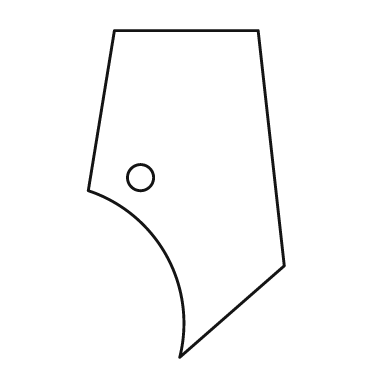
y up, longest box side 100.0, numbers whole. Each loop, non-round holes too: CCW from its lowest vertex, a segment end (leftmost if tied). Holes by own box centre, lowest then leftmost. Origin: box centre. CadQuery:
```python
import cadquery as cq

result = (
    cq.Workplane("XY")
    .moveTo(-2.0, -50.0)
    .lineTo(30.0, -22.0)
    .lineTo(22.0, 50.0)
    .lineTo(-22.0, 50.0)
    .lineTo(-30.0, 1.0)
    .threePointArc((-6.0, -19.0), (-2.0, -50.0))
    .close()
    .moveTo(-14.0, 5.0)
    .circle(4.0)
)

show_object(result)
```